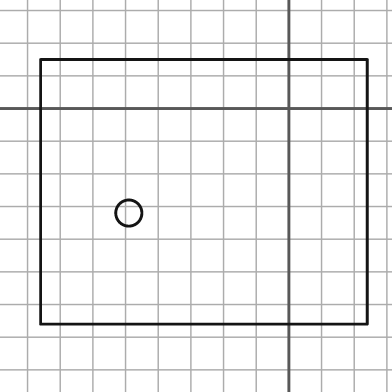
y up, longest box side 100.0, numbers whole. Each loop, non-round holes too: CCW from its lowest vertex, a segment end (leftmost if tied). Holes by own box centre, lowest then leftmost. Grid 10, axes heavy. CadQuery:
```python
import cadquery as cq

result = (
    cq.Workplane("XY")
    .moveTo(-76.0, -66.0)
    .lineTo(24.0, -66.0)
    .lineTo(24.0, 15.0)
    .lineTo(-76.0, 15.0)
    .close()
    .moveTo(-49.0, -32.0)
    .circle(4.0)
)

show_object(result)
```